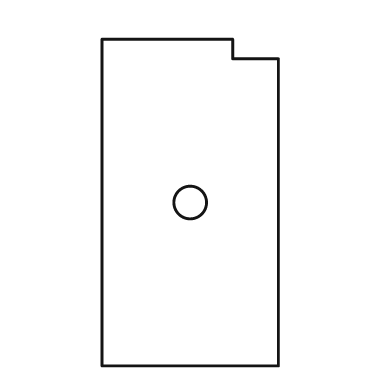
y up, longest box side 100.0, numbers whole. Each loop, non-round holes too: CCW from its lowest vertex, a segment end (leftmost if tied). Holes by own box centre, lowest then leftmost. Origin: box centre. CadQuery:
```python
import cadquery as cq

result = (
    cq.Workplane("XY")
    .moveTo(-27.0, -50.0)
    .lineTo(27.0, -50.0)
    .lineTo(27.0, 44.0)
    .lineTo(13.0, 44.0)
    .lineTo(13.0, 50.0)
    .lineTo(-27.0, 50.0)
    .close()
    .moveTo(0.0, 0.0)
    .circle(5.0)
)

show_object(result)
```